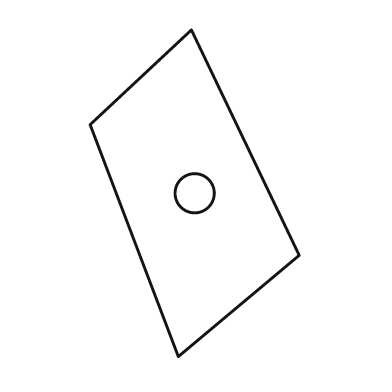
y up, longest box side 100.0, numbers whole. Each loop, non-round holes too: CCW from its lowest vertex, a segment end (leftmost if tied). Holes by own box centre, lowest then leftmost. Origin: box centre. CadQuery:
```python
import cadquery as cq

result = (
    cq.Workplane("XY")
    .moveTo(-5.0, -50.0)
    .lineTo(32.0, -19.0)
    .lineTo(-1.0, 50.0)
    .lineTo(-32.0, 21.0)
    .close()
    .moveTo(0.0, 0.0)
    .circle(6.0)
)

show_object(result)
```